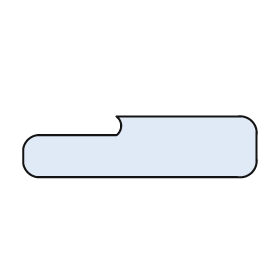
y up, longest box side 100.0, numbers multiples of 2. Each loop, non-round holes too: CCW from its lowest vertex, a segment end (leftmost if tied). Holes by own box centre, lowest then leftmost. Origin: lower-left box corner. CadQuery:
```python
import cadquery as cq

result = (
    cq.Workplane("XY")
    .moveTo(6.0, 0.0)
    .lineTo(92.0, 0.0)
    .threePointArc((98.0, 2.0), (100.0, 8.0))
    .lineTo(100.0, 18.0)
    .threePointArc((98.0, 24.0), (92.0, 26.0))
    .lineTo(40.0, 26.0)
    .threePointArc((42.0, 22.0), (40.0, 18.0))
    .lineTo(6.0, 18.0)
    .threePointArc((2.0, 16.0), (0.0, 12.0))
    .lineTo(0.0, 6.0)
    .threePointArc((2.0, 2.0), (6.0, 0.0))
    .close()
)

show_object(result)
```